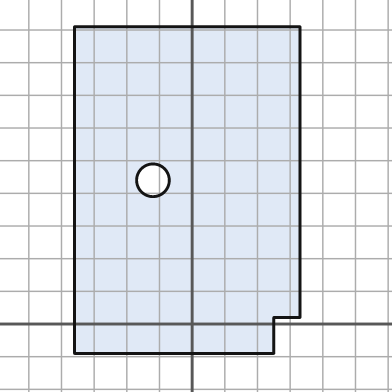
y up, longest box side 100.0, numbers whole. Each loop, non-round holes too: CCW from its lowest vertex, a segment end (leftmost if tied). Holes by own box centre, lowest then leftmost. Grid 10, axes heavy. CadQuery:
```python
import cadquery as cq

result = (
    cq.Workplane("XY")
    .moveTo(-36.0, -9.0)
    .lineTo(25.0, -9.0)
    .lineTo(25.0, 2.0)
    .lineTo(33.0, 2.0)
    .lineTo(33.0, 91.0)
    .lineTo(-36.0, 91.0)
    .close()
    .moveTo(-12.0, 44.0)
    .circle(5.0)
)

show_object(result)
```